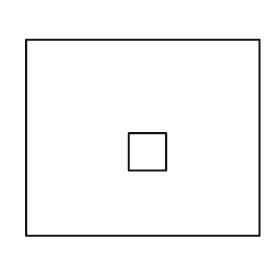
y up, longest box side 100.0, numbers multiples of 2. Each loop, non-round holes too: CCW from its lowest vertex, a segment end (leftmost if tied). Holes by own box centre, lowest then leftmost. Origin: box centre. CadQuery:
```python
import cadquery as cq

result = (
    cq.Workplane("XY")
    .moveTo(-50.0, -42.0)
    .lineTo(50.0, -42.0)
    .lineTo(50.0, 42.0)
    .lineTo(-50.0, 42.0)
    .close()
    .moveTo(-6.0, -14.0)
    .lineTo(10.0, -14.0)
    .lineTo(10.0, 2.0)
    .lineTo(-6.0, 2.0)
    .close()
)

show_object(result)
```